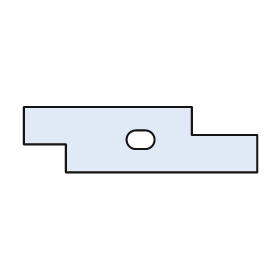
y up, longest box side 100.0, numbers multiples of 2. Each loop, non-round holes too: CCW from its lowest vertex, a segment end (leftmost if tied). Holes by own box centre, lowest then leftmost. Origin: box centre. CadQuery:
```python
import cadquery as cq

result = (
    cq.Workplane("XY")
    .moveTo(-32.0, -14.0)
    .lineTo(50.0, -14.0)
    .lineTo(50.0, 2.0)
    .lineTo(22.0, 2.0)
    .lineTo(22.0, 14.0)
    .lineTo(-50.0, 14.0)
    .lineTo(-50.0, -2.0)
    .lineTo(-32.0, -2.0)
    .close()
    .moveTo(-2.0, -4.0)
    .lineTo(2.0, -4.0)
    .threePointArc((6.0, 0.0), (2.0, 4.0))
    .lineTo(-2.0, 4.0)
    .threePointArc((-6.0, 0.0), (-2.0, -4.0))
    .close()
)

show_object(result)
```